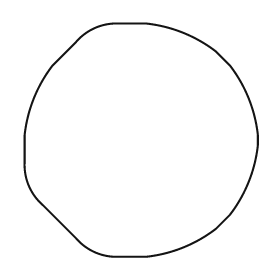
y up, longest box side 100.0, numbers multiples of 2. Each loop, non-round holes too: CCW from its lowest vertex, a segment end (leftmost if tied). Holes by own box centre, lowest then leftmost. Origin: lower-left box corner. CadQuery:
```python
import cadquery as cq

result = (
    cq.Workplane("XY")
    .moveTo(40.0, 0.0)
    .lineTo(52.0, 0.0)
    .threePointArc((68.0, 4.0), (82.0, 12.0))
    .lineTo(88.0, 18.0)
    .threePointArc((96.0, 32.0), (100.0, 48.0))
    .lineTo(100.0, 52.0)
    .threePointArc((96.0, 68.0), (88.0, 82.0))
    .lineTo(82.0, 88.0)
    .threePointArc((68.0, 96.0), (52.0, 100.0))
    .lineTo(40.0, 100.0)
    .threePointArc((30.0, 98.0), (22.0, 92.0))
    .lineTo(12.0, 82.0)
    .threePointArc((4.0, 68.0), (0.0, 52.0))
    .lineTo(0.0, 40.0)
    .threePointArc((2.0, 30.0), (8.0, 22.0))
    .lineTo(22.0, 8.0)
    .threePointArc((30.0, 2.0), (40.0, 0.0))
    .close()
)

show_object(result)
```